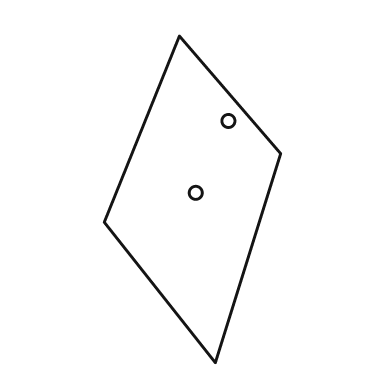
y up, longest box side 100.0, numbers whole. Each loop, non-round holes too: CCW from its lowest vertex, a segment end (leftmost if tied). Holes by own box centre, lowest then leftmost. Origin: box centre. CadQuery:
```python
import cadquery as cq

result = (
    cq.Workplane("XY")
    .moveTo(7.0, -50.0)
    .lineTo(27.0, 14.0)
    .lineTo(-4.0, 50.0)
    .lineTo(-27.0, -7.0)
    .close()
    .moveTo(1.0, 2.0)
    .circle(2.0)
    .moveTo(11.0, 24.0)
    .circle(2.0)
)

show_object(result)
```